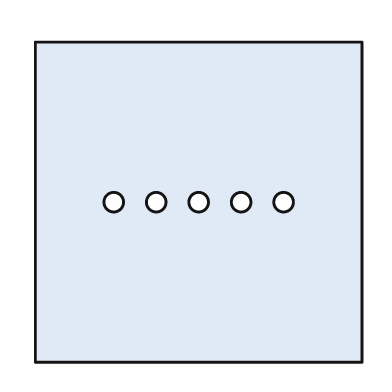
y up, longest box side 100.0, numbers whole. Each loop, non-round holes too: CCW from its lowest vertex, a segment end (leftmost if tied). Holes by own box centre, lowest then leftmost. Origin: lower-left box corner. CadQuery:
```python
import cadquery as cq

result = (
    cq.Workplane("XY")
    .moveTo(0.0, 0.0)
    .lineTo(100.0, 0.0)
    .lineTo(100.0, 98.0)
    .lineTo(0.0, 98.0)
    .close()
    .moveTo(24.0, 49.0)
    .circle(3.0)
    .moveTo(37.0, 49.0)
    .circle(3.0)
    .moveTo(50.0, 49.0)
    .circle(3.0)
    .moveTo(63.0, 49.0)
    .circle(3.0)
    .moveTo(76.0, 49.0)
    .circle(3.0)
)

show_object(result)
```